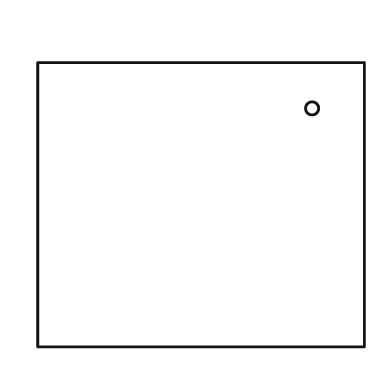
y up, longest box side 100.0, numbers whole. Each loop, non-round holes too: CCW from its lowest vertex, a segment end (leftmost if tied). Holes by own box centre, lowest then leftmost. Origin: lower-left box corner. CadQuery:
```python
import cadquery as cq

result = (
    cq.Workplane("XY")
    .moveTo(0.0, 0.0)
    .lineTo(100.0, 0.0)
    .lineTo(100.0, 87.0)
    .lineTo(0.0, 87.0)
    .close()
    .moveTo(84.0, 73.0)
    .circle(2.0)
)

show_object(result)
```